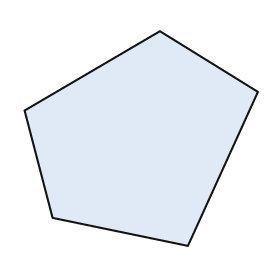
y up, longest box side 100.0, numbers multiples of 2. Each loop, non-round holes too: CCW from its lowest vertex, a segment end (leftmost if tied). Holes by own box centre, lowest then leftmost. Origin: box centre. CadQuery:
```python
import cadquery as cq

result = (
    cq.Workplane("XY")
    .moveTo(20.0, -46.0)
    .lineTo(50.0, 20.0)
    .lineTo(8.0, 46.0)
    .lineTo(-50.0, 12.0)
    .lineTo(-38.0, -34.0)
    .close()
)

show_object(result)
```